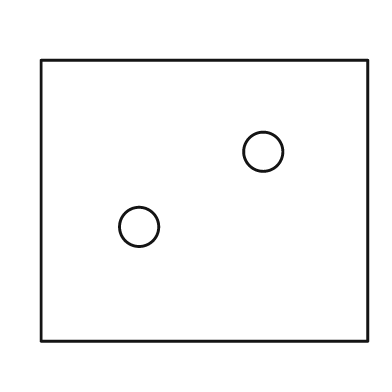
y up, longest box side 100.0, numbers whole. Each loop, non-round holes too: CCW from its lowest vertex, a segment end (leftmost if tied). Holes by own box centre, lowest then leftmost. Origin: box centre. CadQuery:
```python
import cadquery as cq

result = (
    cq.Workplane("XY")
    .moveTo(-50.0, -43.0)
    .lineTo(50.0, -43.0)
    .lineTo(50.0, 43.0)
    .lineTo(-50.0, 43.0)
    .close()
    .moveTo(-20.0, -8.0)
    .circle(6.0)
    .moveTo(18.0, 15.0)
    .circle(6.0)
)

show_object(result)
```